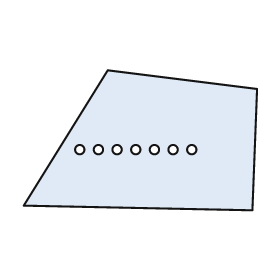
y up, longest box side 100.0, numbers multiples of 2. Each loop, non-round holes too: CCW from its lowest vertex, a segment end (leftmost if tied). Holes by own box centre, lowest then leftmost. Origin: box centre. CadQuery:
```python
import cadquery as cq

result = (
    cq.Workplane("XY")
    .moveTo(48.0, -30.0)
    .lineTo(50.0, 22.0)
    .lineTo(-14.0, 30.0)
    .lineTo(-50.0, -28.0)
    .close()
    .moveTo(-26.0, -4.0)
    .circle(2.0)
    .moveTo(-18.0, -4.0)
    .circle(2.0)
    .moveTo(-10.0, -4.0)
    .circle(2.0)
    .moveTo(-2.0, -4.0)
    .circle(2.0)
    .moveTo(6.0, -4.0)
    .circle(2.0)
    .moveTo(14.0, -4.0)
    .circle(2.0)
    .moveTo(22.0, -4.0)
    .circle(2.0)
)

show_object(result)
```